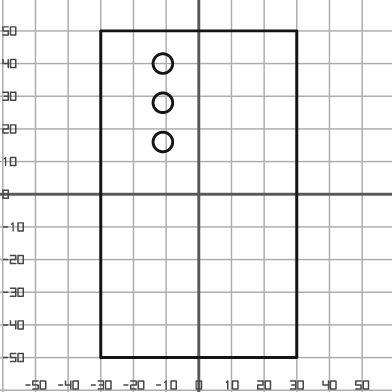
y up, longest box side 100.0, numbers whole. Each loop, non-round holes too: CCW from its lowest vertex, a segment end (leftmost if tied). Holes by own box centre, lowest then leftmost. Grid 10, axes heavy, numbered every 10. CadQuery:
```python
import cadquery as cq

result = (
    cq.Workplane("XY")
    .moveTo(-30.0, -50.0)
    .lineTo(30.0, -50.0)
    .lineTo(30.0, 50.0)
    .lineTo(-30.0, 50.0)
    .close()
    .moveTo(-11.0, 16.0)
    .circle(3.0)
    .moveTo(-11.0, 28.0)
    .circle(3.0)
    .moveTo(-11.0, 40.0)
    .circle(3.0)
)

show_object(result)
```